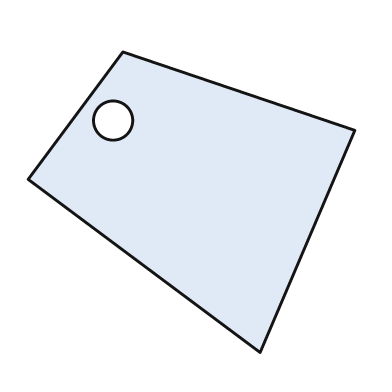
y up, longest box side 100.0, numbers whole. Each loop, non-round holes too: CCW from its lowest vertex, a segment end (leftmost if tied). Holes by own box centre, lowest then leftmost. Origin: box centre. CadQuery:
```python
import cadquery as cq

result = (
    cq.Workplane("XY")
    .moveTo(21.0, -46.0)
    .lineTo(50.0, 22.0)
    .lineTo(-21.0, 46.0)
    .lineTo(-50.0, 7.0)
    .close()
    .moveTo(-24.0, 25.0)
    .circle(6.0)
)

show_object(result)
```